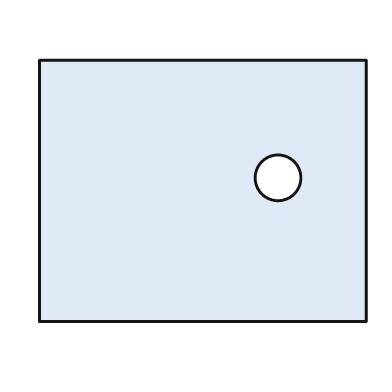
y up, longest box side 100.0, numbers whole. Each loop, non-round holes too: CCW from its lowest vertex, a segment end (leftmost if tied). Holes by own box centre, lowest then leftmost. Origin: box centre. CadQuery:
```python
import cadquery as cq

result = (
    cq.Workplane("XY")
    .moveTo(-50.0, -40.0)
    .lineTo(50.0, -40.0)
    .lineTo(50.0, 40.0)
    .lineTo(-50.0, 40.0)
    .close()
    .moveTo(23.0, 4.0)
    .circle(7.0)
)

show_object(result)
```